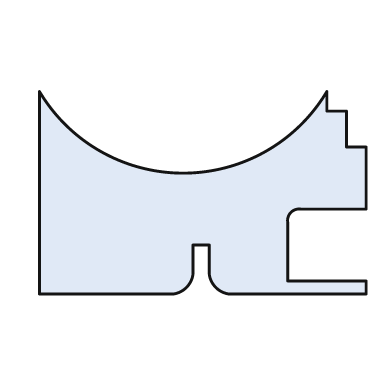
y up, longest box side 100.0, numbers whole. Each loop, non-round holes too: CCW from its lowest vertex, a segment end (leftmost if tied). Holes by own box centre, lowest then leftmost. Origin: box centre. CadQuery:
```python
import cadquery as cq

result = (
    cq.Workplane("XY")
    .moveTo(-50.0, -31.0)
    .lineTo(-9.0, -31.0)
    .threePointArc((-5.0, -29.0), (-3.0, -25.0))
    .lineTo(-3.0, -16.0)
    .lineTo(2.0, -16.0)
    .lineTo(2.0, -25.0)
    .threePointArc((4.0, -29.0), (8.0, -31.0))
    .lineTo(50.0, -31.0)
    .lineTo(50.0, -27.0)
    .lineTo(26.0, -27.0)
    .lineTo(26.0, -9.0)
    .threePointArc((27.0, -6.0), (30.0, -5.0))
    .lineTo(50.0, -5.0)
    .lineTo(50.0, 14.0)
    .lineTo(44.0, 14.0)
    .lineTo(44.0, 25.0)
    .lineTo(38.0, 25.0)
    .lineTo(38.0, 31.0)
    .threePointArc((-6.0, 6.0), (-50.0, 31.0))
    .close()
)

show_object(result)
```